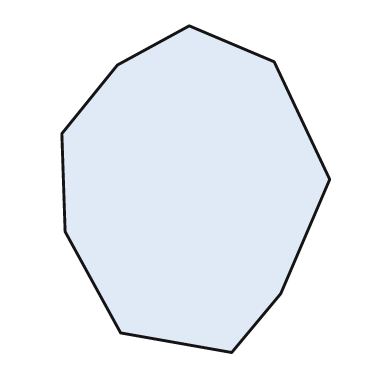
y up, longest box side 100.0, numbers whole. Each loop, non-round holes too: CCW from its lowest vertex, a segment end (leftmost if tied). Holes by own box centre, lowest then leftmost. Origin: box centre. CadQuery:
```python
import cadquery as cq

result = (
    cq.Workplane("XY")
    .moveTo(11.0, -50.0)
    .lineTo(26.0, -32.0)
    .lineTo(41.0, 3.0)
    .lineTo(24.0, 39.0)
    .lineTo(-2.0, 50.0)
    .lineTo(-24.0, 38.0)
    .lineTo(-41.0, 17.0)
    .lineTo(-40.0, -13.0)
    .lineTo(-23.0, -44.0)
    .close()
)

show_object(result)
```